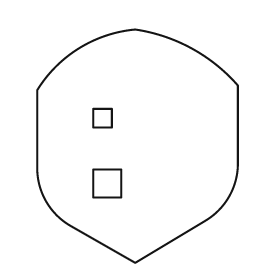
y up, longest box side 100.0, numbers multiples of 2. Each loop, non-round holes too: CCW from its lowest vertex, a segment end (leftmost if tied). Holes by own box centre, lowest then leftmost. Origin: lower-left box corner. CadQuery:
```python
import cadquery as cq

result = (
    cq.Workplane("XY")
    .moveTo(42.0, 0.0)
    .lineTo(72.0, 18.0)
    .threePointArc((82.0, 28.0), (86.0, 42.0))
    .lineTo(86.0, 76.0)
    .threePointArc((66.0, 92.0), (42.0, 100.0))
    .threePointArc((18.0, 92.0), (0.0, 74.0))
    .lineTo(0.0, 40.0)
    .threePointArc((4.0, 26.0), (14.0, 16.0))
    .close()
    .moveTo(24.0, 28.0)
    .lineTo(36.0, 28.0)
    .lineTo(36.0, 40.0)
    .lineTo(24.0, 40.0)
    .close()
    .moveTo(24.0, 58.0)
    .lineTo(32.0, 58.0)
    .lineTo(32.0, 66.0)
    .lineTo(24.0, 66.0)
    .close()
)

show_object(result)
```